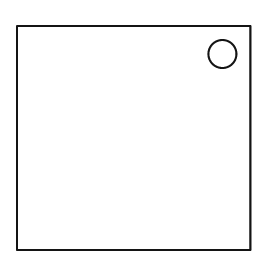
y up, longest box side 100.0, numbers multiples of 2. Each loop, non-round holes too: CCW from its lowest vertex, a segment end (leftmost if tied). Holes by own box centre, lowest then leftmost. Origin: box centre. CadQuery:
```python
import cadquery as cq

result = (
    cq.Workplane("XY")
    .moveTo(-50.0, -48.0)
    .lineTo(50.0, -48.0)
    .lineTo(50.0, 48.0)
    .lineTo(-50.0, 48.0)
    .close()
    .moveTo(38.0, 36.0)
    .circle(6.0)
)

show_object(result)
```